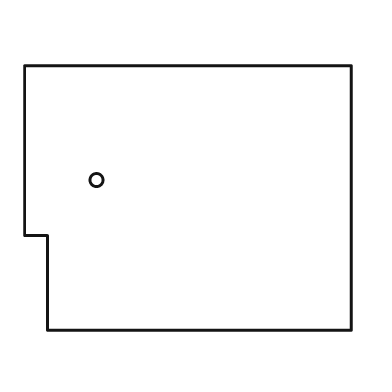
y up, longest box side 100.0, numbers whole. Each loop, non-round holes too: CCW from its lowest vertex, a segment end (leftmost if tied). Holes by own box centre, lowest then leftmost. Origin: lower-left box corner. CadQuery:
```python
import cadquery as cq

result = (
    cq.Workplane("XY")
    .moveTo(7.0, 0.0)
    .lineTo(100.0, 0.0)
    .lineTo(100.0, 81.0)
    .lineTo(0.0, 81.0)
    .lineTo(0.0, 29.0)
    .lineTo(7.0, 29.0)
    .close()
    .moveTo(22.0, 46.0)
    .circle(2.0)
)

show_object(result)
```